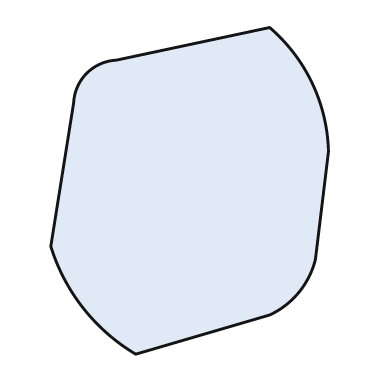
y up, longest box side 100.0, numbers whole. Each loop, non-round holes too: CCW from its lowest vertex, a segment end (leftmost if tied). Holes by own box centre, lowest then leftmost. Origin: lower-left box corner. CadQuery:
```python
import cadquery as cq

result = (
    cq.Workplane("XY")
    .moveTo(26.0, 0.0)
    .lineTo(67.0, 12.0)
    .threePointArc((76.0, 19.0), (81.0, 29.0))
    .lineTo(85.0, 62.0)
    .threePointArc((80.0, 83.0), (67.0, 100.0))
    .lineTo(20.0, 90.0)
    .threePointArc((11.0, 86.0), (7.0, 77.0))
    .lineTo(0.0, 33.0)
    .threePointArc((10.0, 14.0), (26.0, 0.0))
    .close()
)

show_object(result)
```